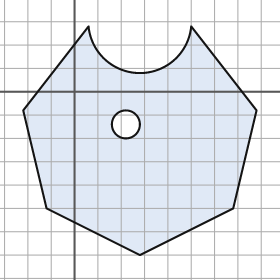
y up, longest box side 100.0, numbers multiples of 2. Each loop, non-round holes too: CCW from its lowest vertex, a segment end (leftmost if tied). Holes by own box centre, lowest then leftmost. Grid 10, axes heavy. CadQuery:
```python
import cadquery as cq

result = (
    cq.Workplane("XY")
    .moveTo(28.0, -70.0)
    .lineTo(68.0, -50.0)
    .lineTo(78.0, -8.0)
    .lineTo(50.0, 28.0)
    .threePointArc((28.0, 8.0), (6.0, 28.0))
    .lineTo(-22.0, -8.0)
    .lineTo(-12.0, -50.0)
    .close()
    .moveTo(22.0, -14.0)
    .circle(6.0)
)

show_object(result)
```